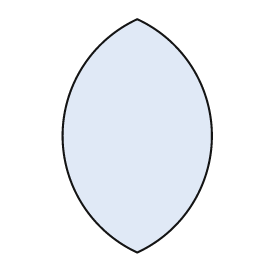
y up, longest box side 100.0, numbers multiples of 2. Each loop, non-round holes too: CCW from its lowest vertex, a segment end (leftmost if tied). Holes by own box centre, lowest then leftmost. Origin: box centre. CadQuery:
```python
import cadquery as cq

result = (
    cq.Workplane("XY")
    .moveTo(0.0, -50.0)
    .threePointArc((32.0, 0.0), (0.0, 50.0))
    .threePointArc((-32.0, 0.0), (0.0, -50.0))
    .close()
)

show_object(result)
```